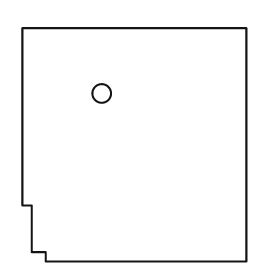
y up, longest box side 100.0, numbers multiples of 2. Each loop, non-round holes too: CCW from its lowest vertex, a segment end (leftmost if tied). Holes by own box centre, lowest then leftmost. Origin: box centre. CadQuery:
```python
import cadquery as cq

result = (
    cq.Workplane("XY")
    .moveTo(-38.0, -50.0)
    .lineTo(48.0, -50.0)
    .lineTo(48.0, 50.0)
    .lineTo(-48.0, 50.0)
    .lineTo(-48.0, -26.0)
    .lineTo(-44.0, -26.0)
    .lineTo(-44.0, -46.0)
    .lineTo(-38.0, -46.0)
    .close()
    .moveTo(-14.0, 22.0)
    .circle(4.0)
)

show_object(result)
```